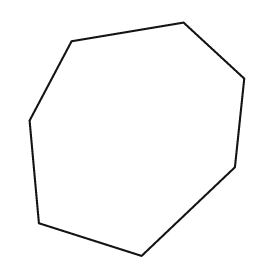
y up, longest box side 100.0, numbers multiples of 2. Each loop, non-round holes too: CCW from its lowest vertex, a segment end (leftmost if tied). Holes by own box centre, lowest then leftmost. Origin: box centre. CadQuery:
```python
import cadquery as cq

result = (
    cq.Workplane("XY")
    .moveTo(2.0, -50.0)
    .lineTo(42.0, -12.0)
    .lineTo(46.0, 26.0)
    .lineTo(20.0, 50.0)
    .lineTo(-28.0, 42.0)
    .lineTo(-46.0, 8.0)
    .lineTo(-42.0, -36.0)
    .close()
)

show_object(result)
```